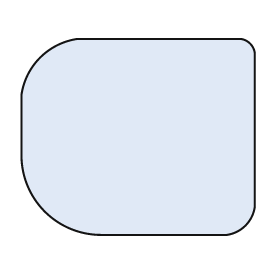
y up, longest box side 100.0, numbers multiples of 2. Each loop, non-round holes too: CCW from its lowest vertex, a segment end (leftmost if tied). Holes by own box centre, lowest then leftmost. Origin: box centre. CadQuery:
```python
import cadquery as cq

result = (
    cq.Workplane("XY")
    .moveTo(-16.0, -42.0)
    .lineTo(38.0, -42.0)
    .threePointArc((46.0, -38.0), (50.0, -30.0))
    .lineTo(50.0, 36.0)
    .threePointArc((48.0, 40.0), (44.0, 42.0))
    .lineTo(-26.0, 42.0)
    .threePointArc((-42.0, 34.0), (-50.0, 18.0))
    .lineTo(-50.0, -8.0)
    .threePointArc((-40.0, -32.0), (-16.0, -42.0))
    .close()
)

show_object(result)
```